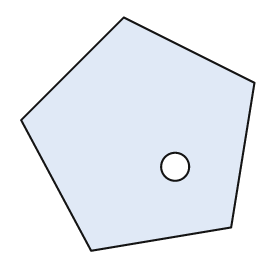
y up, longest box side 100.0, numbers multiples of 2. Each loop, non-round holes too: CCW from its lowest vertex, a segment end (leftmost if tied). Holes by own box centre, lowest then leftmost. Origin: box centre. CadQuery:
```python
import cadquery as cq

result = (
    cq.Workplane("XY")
    .moveTo(-20.0, -50.0)
    .lineTo(40.0, -40.0)
    .lineTo(50.0, 22.0)
    .lineTo(-6.0, 50.0)
    .lineTo(-50.0, 6.0)
    .close()
    .moveTo(16.0, -14.0)
    .circle(6.0)
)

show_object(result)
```